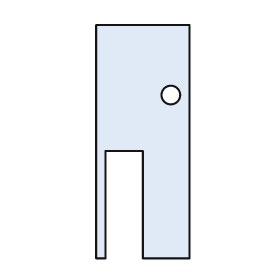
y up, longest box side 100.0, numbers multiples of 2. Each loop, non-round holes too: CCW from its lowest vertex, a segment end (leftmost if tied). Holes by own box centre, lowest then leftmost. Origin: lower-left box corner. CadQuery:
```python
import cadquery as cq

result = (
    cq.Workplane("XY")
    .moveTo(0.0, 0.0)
    .lineTo(4.0, 0.0)
    .lineTo(4.0, 46.0)
    .lineTo(20.0, 46.0)
    .lineTo(20.0, 0.0)
    .lineTo(40.0, 0.0)
    .lineTo(40.0, 100.0)
    .lineTo(0.0, 100.0)
    .close()
    .moveTo(32.0, 70.0)
    .circle(4.0)
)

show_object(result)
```